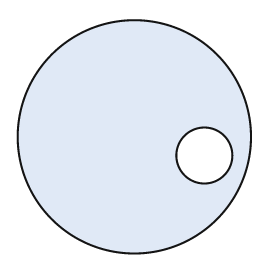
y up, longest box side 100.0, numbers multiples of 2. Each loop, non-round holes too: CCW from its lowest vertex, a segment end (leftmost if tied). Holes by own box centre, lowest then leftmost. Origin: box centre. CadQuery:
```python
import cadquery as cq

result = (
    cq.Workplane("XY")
    .moveTo(0.0, 0.0)
    .circle(50.0)
    .moveTo(30.0, -8.0)
    .circle(12.0)
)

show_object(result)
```